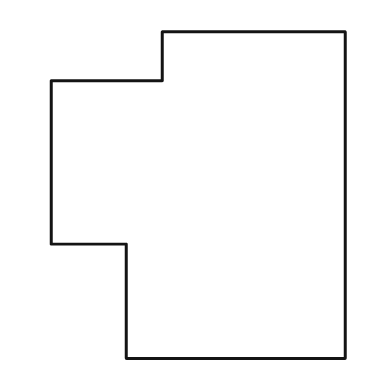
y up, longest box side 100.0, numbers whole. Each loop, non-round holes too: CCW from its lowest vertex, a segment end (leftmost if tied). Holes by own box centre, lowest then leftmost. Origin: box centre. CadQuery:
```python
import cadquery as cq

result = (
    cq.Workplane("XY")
    .moveTo(-22.0, -50.0)
    .lineTo(45.0, -50.0)
    .lineTo(45.0, 50.0)
    .lineTo(-11.0, 50.0)
    .lineTo(-11.0, 35.0)
    .lineTo(-45.0, 35.0)
    .lineTo(-45.0, -15.0)
    .lineTo(-22.0, -15.0)
    .close()
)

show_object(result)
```